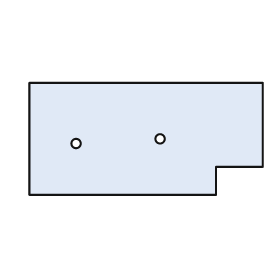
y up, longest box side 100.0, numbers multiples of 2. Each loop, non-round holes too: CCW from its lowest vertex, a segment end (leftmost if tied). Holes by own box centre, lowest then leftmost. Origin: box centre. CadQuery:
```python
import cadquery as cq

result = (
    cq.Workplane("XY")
    .moveTo(-50.0, -24.0)
    .lineTo(30.0, -24.0)
    .lineTo(30.0, -12.0)
    .lineTo(50.0, -12.0)
    .lineTo(50.0, 24.0)
    .lineTo(-50.0, 24.0)
    .close()
    .moveTo(-30.0, -2.0)
    .circle(2.0)
    .moveTo(6.0, 0.0)
    .circle(2.0)
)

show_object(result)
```